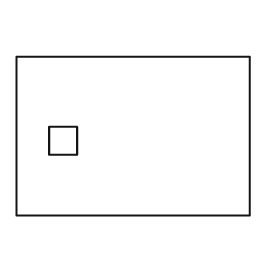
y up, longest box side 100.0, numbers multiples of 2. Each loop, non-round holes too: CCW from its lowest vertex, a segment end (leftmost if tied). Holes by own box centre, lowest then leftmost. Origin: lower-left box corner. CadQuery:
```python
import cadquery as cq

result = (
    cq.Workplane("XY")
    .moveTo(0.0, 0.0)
    .lineTo(100.0, 0.0)
    .lineTo(100.0, 68.0)
    .lineTo(0.0, 68.0)
    .close()
    .moveTo(14.0, 26.0)
    .lineTo(26.0, 26.0)
    .lineTo(26.0, 38.0)
    .lineTo(14.0, 38.0)
    .close()
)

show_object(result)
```